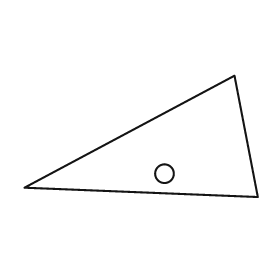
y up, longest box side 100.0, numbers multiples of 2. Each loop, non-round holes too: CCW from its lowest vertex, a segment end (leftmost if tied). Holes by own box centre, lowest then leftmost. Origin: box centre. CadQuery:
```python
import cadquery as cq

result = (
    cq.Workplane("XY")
    .moveTo(50.0, -26.0)
    .lineTo(40.0, 26.0)
    .lineTo(-50.0, -22.0)
    .close()
    .moveTo(10.0, -16.0)
    .circle(4.0)
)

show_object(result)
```